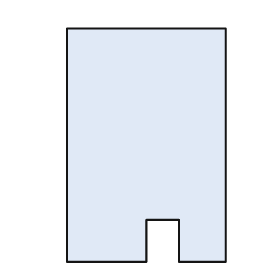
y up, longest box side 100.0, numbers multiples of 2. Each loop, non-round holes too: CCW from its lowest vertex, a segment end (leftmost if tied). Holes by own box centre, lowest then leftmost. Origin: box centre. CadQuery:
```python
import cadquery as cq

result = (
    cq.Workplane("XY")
    .moveTo(-34.0, -50.0)
    .lineTo(0.0, -50.0)
    .lineTo(0.0, -32.0)
    .lineTo(14.0, -32.0)
    .lineTo(14.0, -50.0)
    .lineTo(34.0, -50.0)
    .lineTo(34.0, 50.0)
    .lineTo(-34.0, 50.0)
    .close()
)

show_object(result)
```